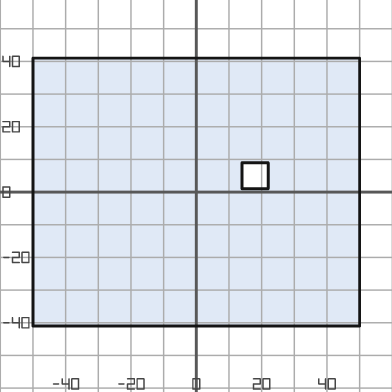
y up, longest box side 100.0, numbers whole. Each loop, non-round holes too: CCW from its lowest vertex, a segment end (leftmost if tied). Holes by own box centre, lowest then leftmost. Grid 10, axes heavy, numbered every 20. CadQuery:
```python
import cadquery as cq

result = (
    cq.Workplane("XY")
    .moveTo(-50.0, -41.0)
    .lineTo(50.0, -41.0)
    .lineTo(50.0, 41.0)
    .lineTo(-50.0, 41.0)
    .close()
    .moveTo(14.0, 1.0)
    .lineTo(22.0, 1.0)
    .lineTo(22.0, 9.0)
    .lineTo(14.0, 9.0)
    .close()
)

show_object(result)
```